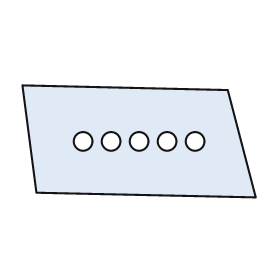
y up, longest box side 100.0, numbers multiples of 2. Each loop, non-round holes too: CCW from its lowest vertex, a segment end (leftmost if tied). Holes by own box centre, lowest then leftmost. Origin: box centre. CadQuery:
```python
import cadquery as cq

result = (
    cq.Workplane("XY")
    .moveTo(50.0, -24.0)
    .lineTo(38.0, 22.0)
    .lineTo(-50.0, 24.0)
    .lineTo(-44.0, -22.0)
    .close()
    .moveTo(-24.0, 0.0)
    .circle(4.0)
    .moveTo(-12.0, 0.0)
    .circle(4.0)
    .moveTo(0.0, 0.0)
    .circle(4.0)
    .moveTo(12.0, 0.0)
    .circle(4.0)
    .moveTo(24.0, 0.0)
    .circle(4.0)
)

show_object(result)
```